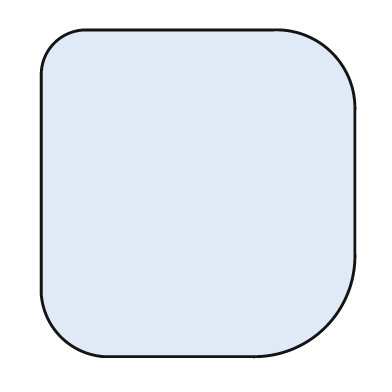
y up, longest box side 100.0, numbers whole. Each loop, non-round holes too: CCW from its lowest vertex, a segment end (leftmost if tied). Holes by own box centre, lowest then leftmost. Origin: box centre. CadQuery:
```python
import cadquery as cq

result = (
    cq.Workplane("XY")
    .moveTo(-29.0, -50.0)
    .lineTo(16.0, -50.0)
    .threePointArc((39.0, -41.0), (48.0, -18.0))
    .lineTo(48.0, 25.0)
    .threePointArc((41.0, 43.0), (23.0, 50.0))
    .lineTo(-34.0, 50.0)
    .threePointArc((-44.0, 46.0), (-48.0, 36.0))
    .lineTo(-48.0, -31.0)
    .threePointArc((-42.0, -44.0), (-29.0, -50.0))
    .close()
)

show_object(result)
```